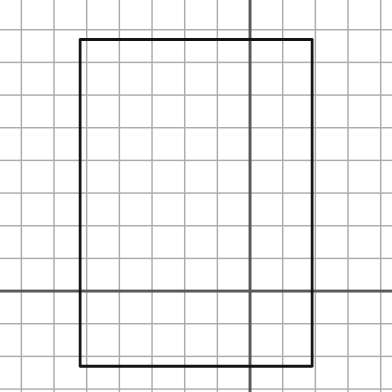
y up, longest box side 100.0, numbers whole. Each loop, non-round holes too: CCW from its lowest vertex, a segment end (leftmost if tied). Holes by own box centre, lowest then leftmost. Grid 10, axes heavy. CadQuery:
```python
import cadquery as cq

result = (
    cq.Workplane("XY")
    .moveTo(-52.0, -23.0)
    .lineTo(19.0, -23.0)
    .lineTo(19.0, 77.0)
    .lineTo(-52.0, 77.0)
    .close()
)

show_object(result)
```